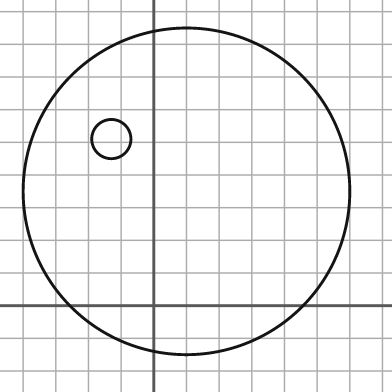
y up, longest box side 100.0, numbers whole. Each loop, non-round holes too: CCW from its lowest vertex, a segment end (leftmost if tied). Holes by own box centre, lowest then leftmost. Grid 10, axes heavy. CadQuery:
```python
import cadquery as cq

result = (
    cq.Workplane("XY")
    .moveTo(10.0, 35.0)
    .circle(50.0)
    .moveTo(-13.0, 51.0)
    .circle(6.0)
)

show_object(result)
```